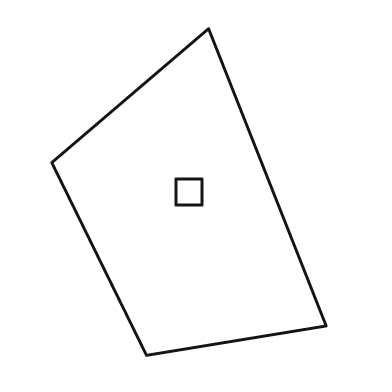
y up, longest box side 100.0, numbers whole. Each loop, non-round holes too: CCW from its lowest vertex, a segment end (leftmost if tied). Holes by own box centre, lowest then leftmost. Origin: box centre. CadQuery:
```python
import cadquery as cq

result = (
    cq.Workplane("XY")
    .moveTo(-13.0, -50.0)
    .lineTo(42.0, -41.0)
    .lineTo(6.0, 50.0)
    .lineTo(-42.0, 9.0)
    .close()
    .moveTo(-4.0, -4.0)
    .lineTo(4.0, -4.0)
    .lineTo(4.0, 4.0)
    .lineTo(-4.0, 4.0)
    .close()
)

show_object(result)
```